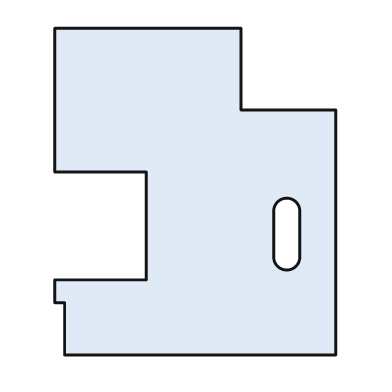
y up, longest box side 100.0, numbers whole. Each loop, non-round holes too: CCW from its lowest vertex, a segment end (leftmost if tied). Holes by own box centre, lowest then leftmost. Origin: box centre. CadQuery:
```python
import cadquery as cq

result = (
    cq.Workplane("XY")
    .moveTo(-40.0, -50.0)
    .lineTo(43.0, -50.0)
    .lineTo(43.0, 25.0)
    .lineTo(14.0, 25.0)
    .lineTo(14.0, 50.0)
    .lineTo(-43.0, 50.0)
    .lineTo(-43.0, 6.0)
    .lineTo(-15.0, 6.0)
    .lineTo(-15.0, -27.0)
    .lineTo(-43.0, -27.0)
    .lineTo(-43.0, -34.0)
    .lineTo(-40.0, -34.0)
    .close()
    .moveTo(24.0, -20.0)
    .threePointArc((28.0, -24.0), (32.0, -20.0))
    .lineTo(32.0, -6.0)
    .threePointArc((28.0, -2.0), (24.0, -6.0))
    .close()
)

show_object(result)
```